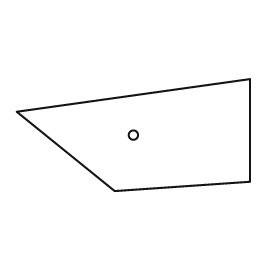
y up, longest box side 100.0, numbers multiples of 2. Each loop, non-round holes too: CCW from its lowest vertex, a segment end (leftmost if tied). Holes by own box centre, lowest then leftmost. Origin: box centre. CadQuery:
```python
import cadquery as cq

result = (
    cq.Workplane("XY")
    .moveTo(-8.0, -24.0)
    .lineTo(50.0, -20.0)
    .lineTo(50.0, 24.0)
    .lineTo(-50.0, 10.0)
    .close()
    .moveTo(0.0, 0.0)
    .circle(2.0)
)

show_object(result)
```